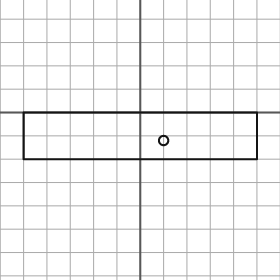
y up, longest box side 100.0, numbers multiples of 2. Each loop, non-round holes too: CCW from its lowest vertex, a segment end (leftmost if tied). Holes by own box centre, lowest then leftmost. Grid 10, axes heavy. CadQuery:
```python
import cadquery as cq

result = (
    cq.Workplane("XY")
    .moveTo(-50.0, -20.0)
    .lineTo(50.0, -20.0)
    .lineTo(50.0, 0.0)
    .lineTo(-50.0, 0.0)
    .close()
    .moveTo(10.0, -12.0)
    .circle(2.0)
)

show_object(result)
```